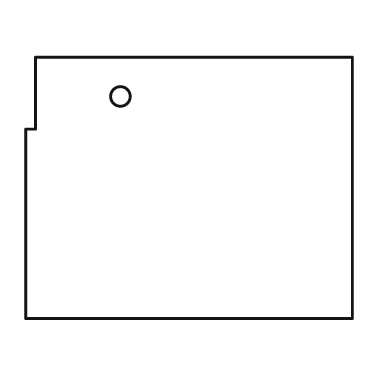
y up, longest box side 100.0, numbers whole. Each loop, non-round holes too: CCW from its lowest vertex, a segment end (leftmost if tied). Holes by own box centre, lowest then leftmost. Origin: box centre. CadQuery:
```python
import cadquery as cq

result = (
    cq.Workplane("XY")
    .moveTo(-50.0, -40.0)
    .lineTo(50.0, -40.0)
    .lineTo(50.0, 40.0)
    .lineTo(-47.0, 40.0)
    .lineTo(-47.0, 18.0)
    .lineTo(-50.0, 18.0)
    .close()
    .moveTo(-21.0, 28.0)
    .circle(3.0)
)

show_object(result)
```